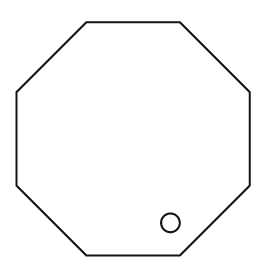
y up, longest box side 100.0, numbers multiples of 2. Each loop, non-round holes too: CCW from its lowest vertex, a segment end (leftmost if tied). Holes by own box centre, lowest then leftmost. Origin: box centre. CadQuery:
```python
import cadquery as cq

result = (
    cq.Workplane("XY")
    .moveTo(-20.0, -50.0)
    .lineTo(20.0, -50.0)
    .lineTo(50.0, -20.0)
    .lineTo(50.0, 20.0)
    .lineTo(20.0, 50.0)
    .lineTo(-20.0, 50.0)
    .lineTo(-50.0, 20.0)
    .lineTo(-50.0, -20.0)
    .close()
    .moveTo(16.0, -36.0)
    .circle(4.0)
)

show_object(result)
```